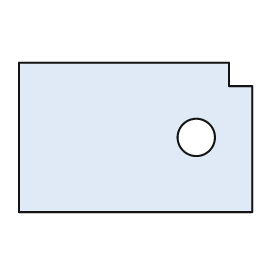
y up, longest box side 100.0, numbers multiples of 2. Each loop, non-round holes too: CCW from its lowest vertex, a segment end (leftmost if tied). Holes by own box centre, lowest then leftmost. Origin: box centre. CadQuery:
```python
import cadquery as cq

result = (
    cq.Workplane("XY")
    .moveTo(-50.0, -32.0)
    .lineTo(50.0, -32.0)
    .lineTo(50.0, 22.0)
    .lineTo(40.0, 22.0)
    .lineTo(40.0, 32.0)
    .lineTo(-50.0, 32.0)
    .close()
    .moveTo(26.0, 0.0)
    .circle(8.0)
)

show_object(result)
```